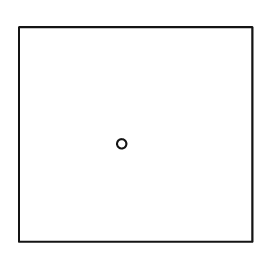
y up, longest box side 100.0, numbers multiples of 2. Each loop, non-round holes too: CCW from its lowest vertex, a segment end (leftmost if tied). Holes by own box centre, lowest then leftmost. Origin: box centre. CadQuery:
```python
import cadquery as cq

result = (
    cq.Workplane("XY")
    .moveTo(-50.0, -46.0)
    .lineTo(50.0, -46.0)
    .lineTo(50.0, 46.0)
    .lineTo(-50.0, 46.0)
    .close()
    .moveTo(-6.0, -4.0)
    .circle(2.0)
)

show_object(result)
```